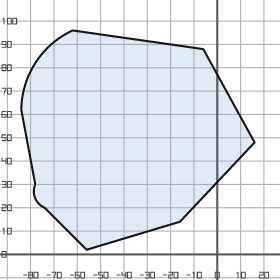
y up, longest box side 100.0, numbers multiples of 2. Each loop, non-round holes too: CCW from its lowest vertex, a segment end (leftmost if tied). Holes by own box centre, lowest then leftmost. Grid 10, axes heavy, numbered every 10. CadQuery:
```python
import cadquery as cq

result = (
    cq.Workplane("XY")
    .moveTo(-56.0, 2.0)
    .lineTo(-16.0, 14.0)
    .lineTo(16.0, 48.0)
    .lineTo(-6.0, 88.0)
    .lineTo(-62.0, 96.0)
    .threePointArc((-78.0, 82.0), (-84.0, 62.0))
    .lineTo(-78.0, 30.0)
    .threePointArc((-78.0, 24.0), (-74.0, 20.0))
    .close()
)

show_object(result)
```